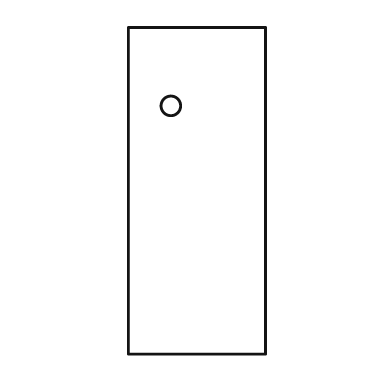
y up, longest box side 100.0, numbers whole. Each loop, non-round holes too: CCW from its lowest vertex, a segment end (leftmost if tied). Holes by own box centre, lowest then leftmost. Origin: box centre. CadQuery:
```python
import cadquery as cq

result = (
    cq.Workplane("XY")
    .moveTo(-21.0, -50.0)
    .lineTo(21.0, -50.0)
    .lineTo(21.0, 50.0)
    .lineTo(-21.0, 50.0)
    .close()
    .moveTo(-8.0, 26.0)
    .circle(3.0)
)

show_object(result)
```